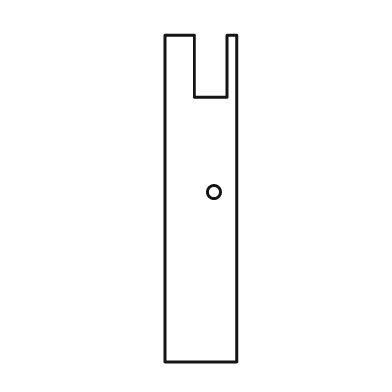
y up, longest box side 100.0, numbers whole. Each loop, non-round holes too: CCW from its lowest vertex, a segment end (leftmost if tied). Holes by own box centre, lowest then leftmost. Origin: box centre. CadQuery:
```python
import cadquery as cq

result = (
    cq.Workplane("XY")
    .moveTo(-11.0, -50.0)
    .lineTo(11.0, -50.0)
    .lineTo(11.0, 50.0)
    .lineTo(8.0, 50.0)
    .lineTo(8.0, 31.0)
    .lineTo(-2.0, 31.0)
    .lineTo(-2.0, 50.0)
    .lineTo(-11.0, 50.0)
    .close()
    .moveTo(4.0, 2.0)
    .circle(2.0)
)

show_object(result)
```